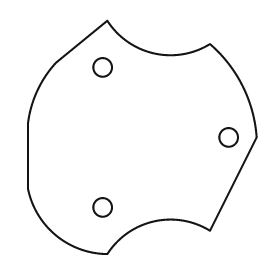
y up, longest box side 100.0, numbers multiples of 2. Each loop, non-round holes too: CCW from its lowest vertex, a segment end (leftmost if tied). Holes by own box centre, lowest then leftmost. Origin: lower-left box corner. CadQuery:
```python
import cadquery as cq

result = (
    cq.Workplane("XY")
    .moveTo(34.0, 0.0)
    .threePointArc((54.0, 14.0), (78.0, 10.0))
    .lineTo(98.0, 50.0)
    .threePointArc((92.0, 72.0), (78.0, 90.0))
    .threePointArc((54.0, 86.0), (34.0, 100.0))
    .lineTo(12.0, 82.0)
    .threePointArc((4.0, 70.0), (0.0, 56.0))
    .lineTo(0.0, 28.0)
    .threePointArc((12.0, 8.0), (34.0, 0.0))
    .close()
    .moveTo(32.0, 20.0)
    .circle(4.0)
    .moveTo(86.0, 50.0)
    .circle(4.0)
    .moveTo(32.0, 80.0)
    .circle(4.0)
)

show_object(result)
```